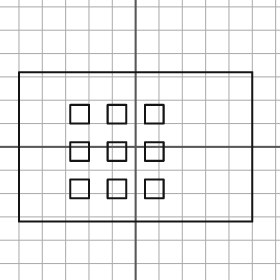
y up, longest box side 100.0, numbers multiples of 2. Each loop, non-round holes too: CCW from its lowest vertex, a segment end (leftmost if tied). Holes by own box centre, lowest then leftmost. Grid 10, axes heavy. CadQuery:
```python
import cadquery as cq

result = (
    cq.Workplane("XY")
    .moveTo(-50.0, -32.0)
    .lineTo(50.0, -32.0)
    .lineTo(50.0, 32.0)
    .lineTo(-50.0, 32.0)
    .close()
    .moveTo(-28.0, -22.0)
    .lineTo(-20.0, -22.0)
    .lineTo(-20.0, -14.0)
    .lineTo(-28.0, -14.0)
    .close()
    .moveTo(-12.0, -22.0)
    .lineTo(-4.0, -22.0)
    .lineTo(-4.0, -14.0)
    .lineTo(-12.0, -14.0)
    .close()
    .moveTo(4.0, -22.0)
    .lineTo(12.0, -22.0)
    .lineTo(12.0, -14.0)
    .lineTo(4.0, -14.0)
    .close()
    .moveTo(-28.0, -6.0)
    .lineTo(-20.0, -6.0)
    .lineTo(-20.0, 2.0)
    .lineTo(-28.0, 2.0)
    .close()
    .moveTo(-12.0, -6.0)
    .lineTo(-4.0, -6.0)
    .lineTo(-4.0, 2.0)
    .lineTo(-12.0, 2.0)
    .close()
    .moveTo(4.0, -6.0)
    .lineTo(12.0, -6.0)
    .lineTo(12.0, 2.0)
    .lineTo(4.0, 2.0)
    .close()
    .moveTo(-28.0, 10.0)
    .lineTo(-20.0, 10.0)
    .lineTo(-20.0, 18.0)
    .lineTo(-28.0, 18.0)
    .close()
    .moveTo(-12.0, 10.0)
    .lineTo(-4.0, 10.0)
    .lineTo(-4.0, 18.0)
    .lineTo(-12.0, 18.0)
    .close()
    .moveTo(4.0, 10.0)
    .lineTo(12.0, 10.0)
    .lineTo(12.0, 18.0)
    .lineTo(4.0, 18.0)
    .close()
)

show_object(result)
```